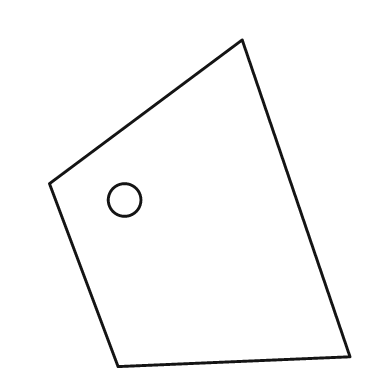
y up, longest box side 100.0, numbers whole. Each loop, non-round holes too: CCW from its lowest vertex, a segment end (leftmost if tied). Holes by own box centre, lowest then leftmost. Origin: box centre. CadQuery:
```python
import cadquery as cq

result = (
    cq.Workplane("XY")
    .moveTo(-25.0, -50.0)
    .lineTo(46.0, -47.0)
    .lineTo(13.0, 50.0)
    .lineTo(-46.0, 6.0)
    .close()
    .moveTo(-23.0, 1.0)
    .circle(5.0)
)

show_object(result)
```